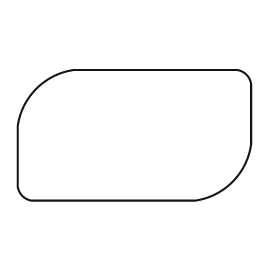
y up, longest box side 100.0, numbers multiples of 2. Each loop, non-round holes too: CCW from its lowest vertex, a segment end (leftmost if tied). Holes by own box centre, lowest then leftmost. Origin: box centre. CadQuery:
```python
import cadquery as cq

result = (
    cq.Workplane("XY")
    .moveTo(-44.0, -28.0)
    .lineTo(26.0, -28.0)
    .threePointArc((42.0, -20.0), (50.0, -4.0))
    .lineTo(50.0, 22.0)
    .threePointArc((48.0, 26.0), (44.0, 28.0))
    .lineTo(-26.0, 28.0)
    .threePointArc((-42.0, 20.0), (-50.0, 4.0))
    .lineTo(-50.0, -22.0)
    .threePointArc((-48.0, -26.0), (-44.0, -28.0))
    .close()
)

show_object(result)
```